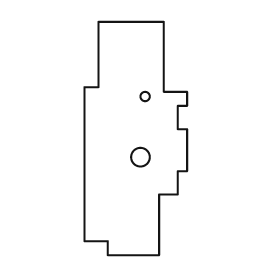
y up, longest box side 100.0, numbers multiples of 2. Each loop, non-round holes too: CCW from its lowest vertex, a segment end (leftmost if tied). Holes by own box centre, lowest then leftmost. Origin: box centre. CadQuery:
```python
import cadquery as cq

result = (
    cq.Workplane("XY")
    .moveTo(-12.0, -50.0)
    .lineTo(10.0, -50.0)
    .lineTo(10.0, -24.0)
    .lineTo(18.0, -24.0)
    .lineTo(18.0, -14.0)
    .lineTo(22.0, -14.0)
    .lineTo(22.0, 4.0)
    .lineTo(18.0, 4.0)
    .lineTo(18.0, 14.0)
    .lineTo(22.0, 14.0)
    .lineTo(22.0, 20.0)
    .lineTo(12.0, 20.0)
    .lineTo(12.0, 50.0)
    .lineTo(-16.0, 50.0)
    .lineTo(-16.0, 22.0)
    .lineTo(-22.0, 22.0)
    .lineTo(-22.0, -44.0)
    .lineTo(-12.0, -44.0)
    .close()
    .moveTo(2.0, -8.0)
    .circle(4.0)
    .moveTo(4.0, 18.0)
    .circle(2.0)
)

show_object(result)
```